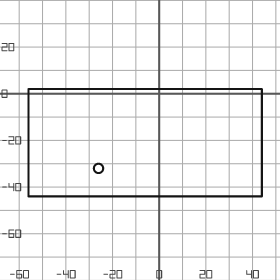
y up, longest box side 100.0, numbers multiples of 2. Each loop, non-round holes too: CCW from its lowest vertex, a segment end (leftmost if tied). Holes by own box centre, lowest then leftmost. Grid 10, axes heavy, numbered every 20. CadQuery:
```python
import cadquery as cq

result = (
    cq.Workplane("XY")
    .moveTo(-56.0, -44.0)
    .lineTo(44.0, -44.0)
    .lineTo(44.0, 2.0)
    .lineTo(-56.0, 2.0)
    .close()
    .moveTo(-26.0, -32.0)
    .circle(2.0)
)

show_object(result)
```